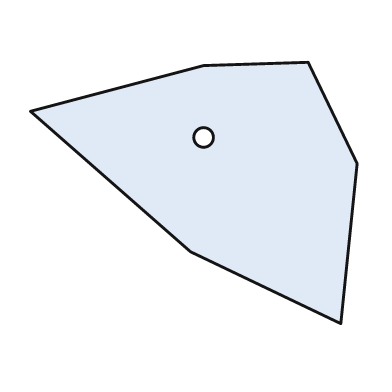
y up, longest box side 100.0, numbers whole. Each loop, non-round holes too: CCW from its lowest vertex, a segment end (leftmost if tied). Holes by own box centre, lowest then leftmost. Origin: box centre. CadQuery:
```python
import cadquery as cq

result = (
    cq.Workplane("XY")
    .moveTo(45.0, -40.0)
    .lineTo(50.0, 9.0)
    .lineTo(35.0, 40.0)
    .lineTo(3.0, 39.0)
    .lineTo(-50.0, 25.0)
    .lineTo(-1.0, -18.0)
    .close()
    .moveTo(3.0, 17.0)
    .circle(3.0)
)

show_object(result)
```